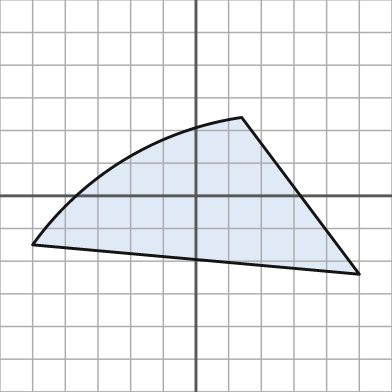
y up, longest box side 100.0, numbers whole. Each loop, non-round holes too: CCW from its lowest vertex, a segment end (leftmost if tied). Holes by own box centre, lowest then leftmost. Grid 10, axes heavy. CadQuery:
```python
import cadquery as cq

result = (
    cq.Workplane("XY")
    .moveTo(50.0, -24.0)
    .lineTo(14.0, 24.0)
    .threePointArc((-22.0, 11.0), (-50.0, -15.0))
    .close()
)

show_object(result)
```